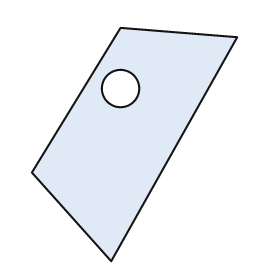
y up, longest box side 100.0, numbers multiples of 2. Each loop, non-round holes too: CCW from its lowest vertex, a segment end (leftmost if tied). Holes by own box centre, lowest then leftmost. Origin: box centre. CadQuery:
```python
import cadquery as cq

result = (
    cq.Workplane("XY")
    .moveTo(-10.0, -50.0)
    .lineTo(44.0, 46.0)
    .lineTo(-6.0, 50.0)
    .lineTo(-44.0, -12.0)
    .close()
    .moveTo(-6.0, 24.0)
    .circle(8.0)
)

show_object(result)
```